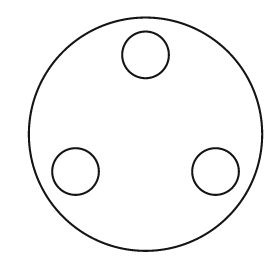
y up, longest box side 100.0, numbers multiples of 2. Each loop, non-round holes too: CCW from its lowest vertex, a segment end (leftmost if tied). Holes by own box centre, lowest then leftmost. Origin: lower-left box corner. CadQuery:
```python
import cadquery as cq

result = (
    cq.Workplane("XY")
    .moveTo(50.0, 50.0)
    .circle(50.0)
    .moveTo(20.0, 34.0)
    .circle(10.0)
    .moveTo(80.0, 34.0)
    .circle(10.0)
    .moveTo(50.0, 84.0)
    .circle(10.0)
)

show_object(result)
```